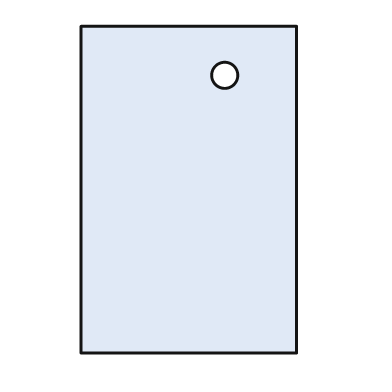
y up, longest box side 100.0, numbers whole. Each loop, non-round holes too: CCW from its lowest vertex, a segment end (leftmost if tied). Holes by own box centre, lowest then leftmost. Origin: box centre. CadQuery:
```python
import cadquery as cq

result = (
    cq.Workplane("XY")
    .moveTo(-33.0, -50.0)
    .lineTo(33.0, -50.0)
    .lineTo(33.0, 50.0)
    .lineTo(-33.0, 50.0)
    .close()
    .moveTo(11.0, 35.0)
    .circle(4.0)
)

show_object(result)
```